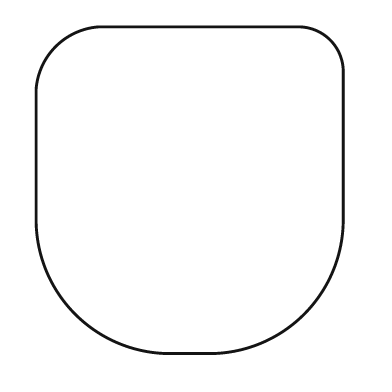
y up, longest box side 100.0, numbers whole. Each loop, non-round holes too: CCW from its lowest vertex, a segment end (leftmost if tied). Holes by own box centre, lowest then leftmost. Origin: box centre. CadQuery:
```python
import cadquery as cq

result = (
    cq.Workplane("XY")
    .moveTo(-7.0, -50.0)
    .lineTo(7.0, -50.0)
    .threePointArc((35.0, -38.0), (47.0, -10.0))
    .lineTo(47.0, 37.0)
    .threePointArc((43.0, 46.0), (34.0, 50.0))
    .lineTo(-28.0, 50.0)
    .threePointArc((-41.0, 44.0), (-47.0, 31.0))
    .lineTo(-47.0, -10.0)
    .threePointArc((-35.0, -38.0), (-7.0, -50.0))
    .close()
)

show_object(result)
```